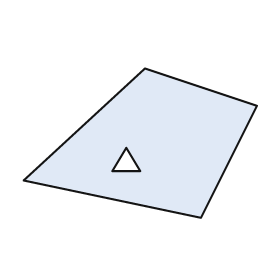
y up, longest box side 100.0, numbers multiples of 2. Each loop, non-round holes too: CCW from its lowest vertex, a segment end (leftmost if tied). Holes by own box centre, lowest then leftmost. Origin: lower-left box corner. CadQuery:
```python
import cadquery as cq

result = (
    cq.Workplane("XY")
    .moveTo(76.0, 0.0)
    .lineTo(100.0, 48.0)
    .lineTo(52.0, 64.0)
    .lineTo(0.0, 16.0)
    .close()
    .moveTo(38.0, 20.0)
    .lineTo(50.0, 20.0)
    .lineTo(44.0, 30.0)
    .close()
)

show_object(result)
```